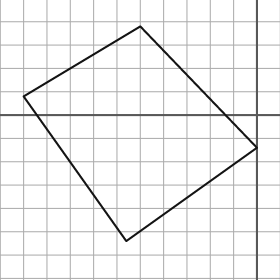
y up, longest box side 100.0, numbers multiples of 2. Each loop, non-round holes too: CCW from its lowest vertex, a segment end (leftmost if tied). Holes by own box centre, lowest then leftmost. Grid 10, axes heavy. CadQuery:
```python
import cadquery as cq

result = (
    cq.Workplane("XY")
    .moveTo(-56.0, -54.0)
    .lineTo(0.0, -14.0)
    .lineTo(-50.0, 38.0)
    .lineTo(-100.0, 8.0)
    .close()
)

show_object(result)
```